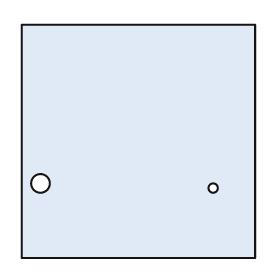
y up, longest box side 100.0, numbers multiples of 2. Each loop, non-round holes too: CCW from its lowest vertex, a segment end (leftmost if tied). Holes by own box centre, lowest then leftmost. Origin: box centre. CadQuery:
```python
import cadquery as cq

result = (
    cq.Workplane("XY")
    .moveTo(-50.0, -50.0)
    .lineTo(50.0, -50.0)
    .lineTo(50.0, 50.0)
    .lineTo(-50.0, 50.0)
    .close()
    .moveTo(32.0, -20.0)
    .circle(2.0)
    .moveTo(-42.0, -18.0)
    .circle(4.0)
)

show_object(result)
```